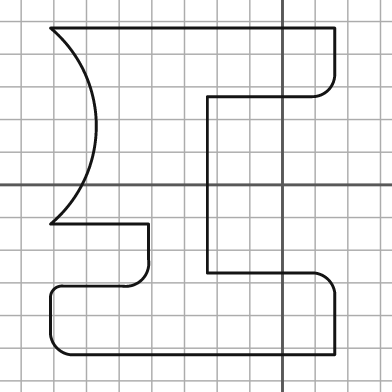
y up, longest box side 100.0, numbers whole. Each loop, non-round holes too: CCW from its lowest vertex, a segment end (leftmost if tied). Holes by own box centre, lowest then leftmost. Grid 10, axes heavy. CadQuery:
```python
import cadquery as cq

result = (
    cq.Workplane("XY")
    .moveTo(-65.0, -52.0)
    .lineTo(16.0, -52.0)
    .lineTo(16.0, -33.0)
    .threePointArc((14.0, -29.0), (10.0, -27.0))
    .lineTo(-23.0, -27.0)
    .lineTo(-23.0, 27.0)
    .lineTo(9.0, 27.0)
    .threePointArc((14.0, 29.0), (16.0, 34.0))
    .lineTo(16.0, 48.0)
    .lineTo(-71.0, 48.0)
    .threePointArc((-57.0, 18.0), (-71.0, -12.0))
    .lineTo(-41.0, -12.0)
    .lineTo(-41.0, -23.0)
    .threePointArc((-43.0, -29.0), (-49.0, -31.0))
    .lineTo(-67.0, -31.0)
    .threePointArc((-70.0, -32.0), (-71.0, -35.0))
    .lineTo(-71.0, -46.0)
    .threePointArc((-69.0, -50.0), (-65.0, -52.0))
    .close()
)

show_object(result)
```